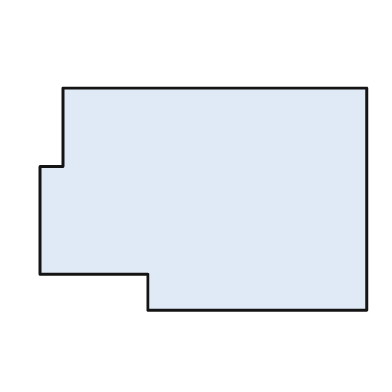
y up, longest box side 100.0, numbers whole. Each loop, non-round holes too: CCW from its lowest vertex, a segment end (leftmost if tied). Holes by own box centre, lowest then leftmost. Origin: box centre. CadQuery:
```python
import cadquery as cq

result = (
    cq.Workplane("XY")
    .moveTo(-17.0, -34.0)
    .lineTo(50.0, -34.0)
    .lineTo(50.0, 34.0)
    .lineTo(-43.0, 34.0)
    .lineTo(-43.0, 10.0)
    .lineTo(-50.0, 10.0)
    .lineTo(-50.0, -23.0)
    .lineTo(-17.0, -23.0)
    .close()
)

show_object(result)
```